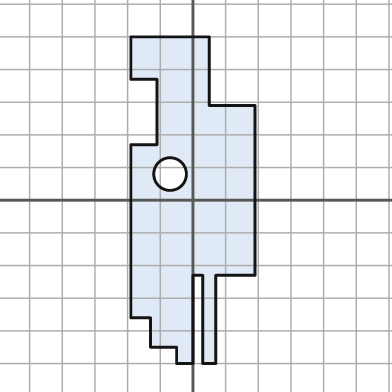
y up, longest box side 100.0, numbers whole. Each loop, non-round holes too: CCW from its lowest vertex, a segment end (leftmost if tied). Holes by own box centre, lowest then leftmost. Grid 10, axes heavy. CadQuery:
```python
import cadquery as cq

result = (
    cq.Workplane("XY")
    .moveTo(-5.0, -50.0)
    .lineTo(0.0, -50.0)
    .lineTo(0.0, -23.0)
    .lineTo(3.0, -23.0)
    .lineTo(3.0, -50.0)
    .lineTo(7.0, -50.0)
    .lineTo(7.0, -23.0)
    .lineTo(19.0, -23.0)
    .lineTo(19.0, 29.0)
    .lineTo(5.0, 29.0)
    .lineTo(5.0, 50.0)
    .lineTo(-19.0, 50.0)
    .lineTo(-19.0, 37.0)
    .lineTo(-11.0, 37.0)
    .lineTo(-11.0, 17.0)
    .lineTo(-19.0, 17.0)
    .lineTo(-19.0, -36.0)
    .lineTo(-13.0, -36.0)
    .lineTo(-13.0, -45.0)
    .lineTo(-5.0, -45.0)
    .close()
    .moveTo(-7.0, 8.0)
    .circle(5.0)
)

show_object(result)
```